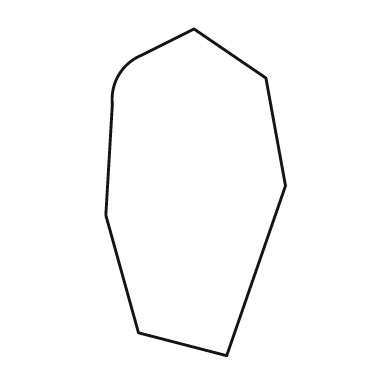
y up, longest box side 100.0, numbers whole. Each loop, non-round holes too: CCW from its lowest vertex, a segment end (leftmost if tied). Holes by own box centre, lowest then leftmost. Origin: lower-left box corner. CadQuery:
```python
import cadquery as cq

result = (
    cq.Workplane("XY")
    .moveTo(37.0, 0.0)
    .lineTo(55.0, 52.0)
    .lineTo(49.0, 85.0)
    .lineTo(27.0, 100.0)
    .lineTo(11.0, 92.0)
    .threePointArc((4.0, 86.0), (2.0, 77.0))
    .lineTo(0.0, 43.0)
    .lineTo(10.0, 7.0)
    .close()
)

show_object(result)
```